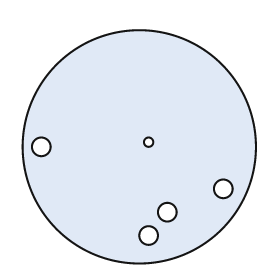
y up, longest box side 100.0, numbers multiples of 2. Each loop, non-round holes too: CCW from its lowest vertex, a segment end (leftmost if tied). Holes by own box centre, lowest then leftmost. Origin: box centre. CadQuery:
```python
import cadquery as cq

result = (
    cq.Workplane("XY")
    .moveTo(0.0, 0.0)
    .circle(50.0)
    .moveTo(4.0, -38.0)
    .circle(4.0)
    .moveTo(12.0, -28.0)
    .circle(4.0)
    .moveTo(36.0, -18.0)
    .circle(4.0)
    .moveTo(-42.0, 0.0)
    .circle(4.0)
    .moveTo(4.0, 2.0)
    .circle(2.0)
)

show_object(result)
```